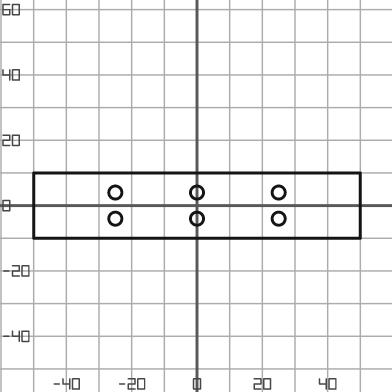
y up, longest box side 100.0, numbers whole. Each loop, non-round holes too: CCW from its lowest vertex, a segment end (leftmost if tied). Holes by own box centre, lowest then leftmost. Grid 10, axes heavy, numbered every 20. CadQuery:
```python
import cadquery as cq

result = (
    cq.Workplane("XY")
    .moveTo(-50.0, -10.0)
    .lineTo(50.0, -10.0)
    .lineTo(50.0, 10.0)
    .lineTo(-50.0, 10.0)
    .close()
    .moveTo(-25.0, -4.0)
    .circle(2.0)
    .moveTo(0.0, -4.0)
    .circle(2.0)
    .moveTo(25.0, -4.0)
    .circle(2.0)
    .moveTo(-25.0, 4.0)
    .circle(2.0)
    .moveTo(0.0, 4.0)
    .circle(2.0)
    .moveTo(25.0, 4.0)
    .circle(2.0)
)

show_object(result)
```